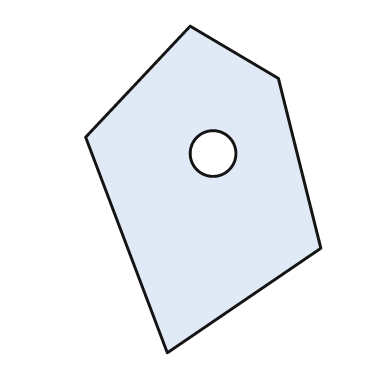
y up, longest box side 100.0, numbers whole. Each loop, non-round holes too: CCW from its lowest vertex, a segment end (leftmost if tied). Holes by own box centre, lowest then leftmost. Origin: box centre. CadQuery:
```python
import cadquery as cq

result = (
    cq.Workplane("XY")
    .moveTo(-11.0, -50.0)
    .lineTo(36.0, -18.0)
    .lineTo(23.0, 34.0)
    .lineTo(-4.0, 50.0)
    .lineTo(-36.0, 16.0)
    .close()
    .moveTo(3.0, 11.0)
    .circle(7.0)
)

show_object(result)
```